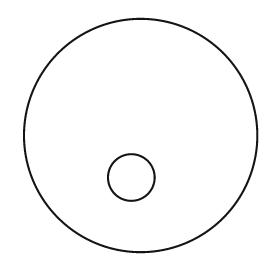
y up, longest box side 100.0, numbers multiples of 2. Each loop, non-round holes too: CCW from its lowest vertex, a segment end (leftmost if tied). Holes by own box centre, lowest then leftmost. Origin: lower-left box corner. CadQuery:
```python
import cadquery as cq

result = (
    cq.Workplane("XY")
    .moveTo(50.0, 50.0)
    .circle(50.0)
    .moveTo(46.0, 32.0)
    .circle(10.0)
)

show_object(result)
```